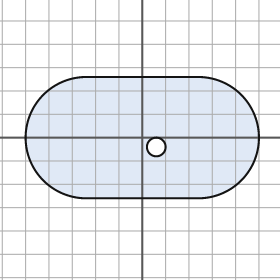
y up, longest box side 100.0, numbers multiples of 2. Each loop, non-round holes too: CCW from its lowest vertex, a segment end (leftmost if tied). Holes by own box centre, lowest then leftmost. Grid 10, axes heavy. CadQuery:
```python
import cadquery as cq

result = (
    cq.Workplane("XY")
    .moveTo(-24.0, -26.0)
    .lineTo(24.0, -26.0)
    .threePointArc((50.0, 0.0), (24.0, 26.0))
    .lineTo(-24.0, 26.0)
    .threePointArc((-50.0, 0.0), (-24.0, -26.0))
    .close()
    .moveTo(6.0, -4.0)
    .circle(4.0)
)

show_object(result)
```